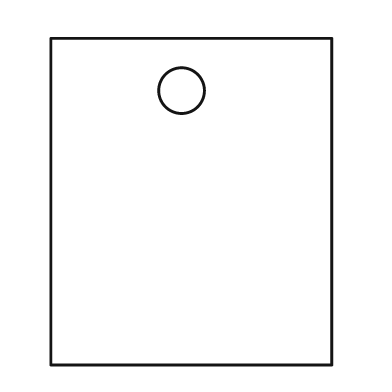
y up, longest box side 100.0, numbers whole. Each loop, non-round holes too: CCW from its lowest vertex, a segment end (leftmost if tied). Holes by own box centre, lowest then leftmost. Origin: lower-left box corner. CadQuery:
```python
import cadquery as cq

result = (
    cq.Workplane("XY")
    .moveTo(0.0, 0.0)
    .lineTo(86.0, 0.0)
    .lineTo(86.0, 100.0)
    .lineTo(0.0, 100.0)
    .close()
    .moveTo(40.0, 84.0)
    .circle(7.0)
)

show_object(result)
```